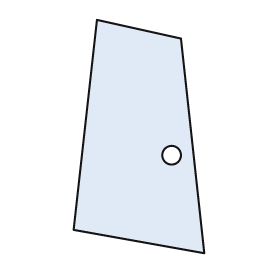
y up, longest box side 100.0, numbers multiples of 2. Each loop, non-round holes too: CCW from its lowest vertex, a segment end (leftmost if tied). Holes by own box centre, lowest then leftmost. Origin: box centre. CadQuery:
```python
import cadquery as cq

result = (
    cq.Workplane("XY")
    .moveTo(28.0, -50.0)
    .lineTo(18.0, 42.0)
    .lineTo(-18.0, 50.0)
    .lineTo(-28.0, -40.0)
    .close()
    .moveTo(14.0, -8.0)
    .circle(4.0)
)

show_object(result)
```